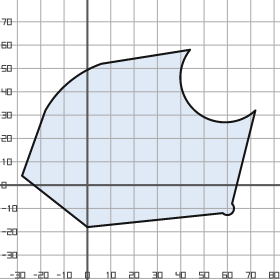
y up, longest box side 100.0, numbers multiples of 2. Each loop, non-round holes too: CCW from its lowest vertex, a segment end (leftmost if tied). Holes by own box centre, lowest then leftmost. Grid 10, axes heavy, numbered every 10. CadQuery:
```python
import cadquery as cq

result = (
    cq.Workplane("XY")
    .moveTo(0.0, -18.0)
    .lineTo(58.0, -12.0)
    .threePointArc((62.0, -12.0), (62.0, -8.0))
    .lineTo(72.0, 32.0)
    .threePointArc((46.0, 32.0), (44.0, 58.0))
    .lineTo(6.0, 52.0)
    .threePointArc((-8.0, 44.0), (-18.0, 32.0))
    .lineTo(-28.0, 4.0)
    .close()
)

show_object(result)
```